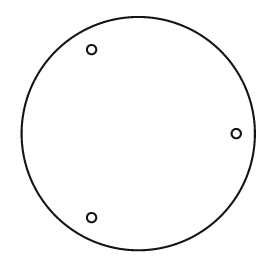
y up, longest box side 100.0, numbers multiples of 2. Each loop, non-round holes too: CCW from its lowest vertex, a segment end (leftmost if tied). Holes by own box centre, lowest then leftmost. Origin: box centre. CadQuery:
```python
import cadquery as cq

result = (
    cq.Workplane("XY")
    .moveTo(0.0, 0.0)
    .circle(50.0)
    .moveTo(-20.0, -36.0)
    .circle(2.0)
    .moveTo(42.0, 0.0)
    .circle(2.0)
    .moveTo(-20.0, 36.0)
    .circle(2.0)
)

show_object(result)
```